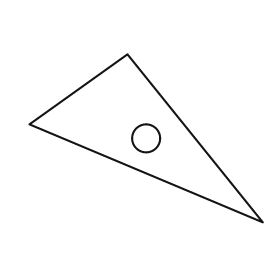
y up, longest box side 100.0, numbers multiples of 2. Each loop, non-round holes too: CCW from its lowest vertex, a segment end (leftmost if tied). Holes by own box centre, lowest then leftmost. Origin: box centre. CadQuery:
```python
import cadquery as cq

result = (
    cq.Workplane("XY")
    .moveTo(50.0, -36.0)
    .lineTo(-8.0, 36.0)
    .lineTo(-50.0, 6.0)
    .close()
    .moveTo(0.0, 0.0)
    .circle(6.0)
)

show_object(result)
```